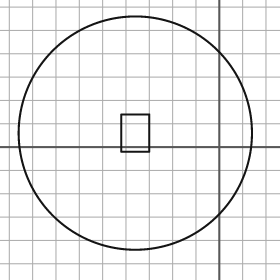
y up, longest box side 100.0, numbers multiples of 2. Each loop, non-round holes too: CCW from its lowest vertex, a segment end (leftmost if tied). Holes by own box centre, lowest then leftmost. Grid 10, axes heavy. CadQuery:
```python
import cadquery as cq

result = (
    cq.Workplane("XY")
    .moveTo(-36.0, 6.0)
    .circle(50.0)
    .moveTo(-42.0, -2.0)
    .lineTo(-30.0, -2.0)
    .lineTo(-30.0, 14.0)
    .lineTo(-42.0, 14.0)
    .close()
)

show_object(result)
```